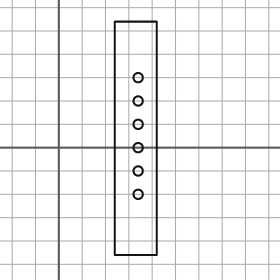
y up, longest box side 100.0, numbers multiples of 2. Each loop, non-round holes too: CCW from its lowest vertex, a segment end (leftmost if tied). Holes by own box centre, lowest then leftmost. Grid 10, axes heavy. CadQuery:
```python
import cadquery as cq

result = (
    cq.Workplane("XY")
    .moveTo(24.0, -46.0)
    .lineTo(42.0, -46.0)
    .lineTo(42.0, 54.0)
    .lineTo(24.0, 54.0)
    .close()
    .moveTo(34.0, -20.0)
    .circle(2.0)
    .moveTo(34.0, -10.0)
    .circle(2.0)
    .moveTo(34.0, 0.0)
    .circle(2.0)
    .moveTo(34.0, 10.0)
    .circle(2.0)
    .moveTo(34.0, 20.0)
    .circle(2.0)
    .moveTo(34.0, 30.0)
    .circle(2.0)
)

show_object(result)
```